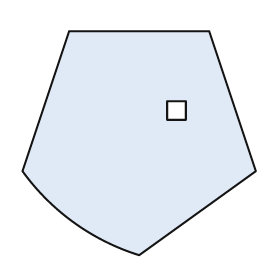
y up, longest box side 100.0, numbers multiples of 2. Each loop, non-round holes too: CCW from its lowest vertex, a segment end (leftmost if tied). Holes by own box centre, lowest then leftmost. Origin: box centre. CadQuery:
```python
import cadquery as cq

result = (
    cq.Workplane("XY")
    .moveTo(0.0, -48.0)
    .lineTo(50.0, -12.0)
    .lineTo(30.0, 48.0)
    .lineTo(-30.0, 48.0)
    .lineTo(-50.0, -12.0)
    .threePointArc((-28.0, -34.0), (0.0, -48.0))
    .close()
    .moveTo(12.0, 10.0)
    .lineTo(20.0, 10.0)
    .lineTo(20.0, 18.0)
    .lineTo(12.0, 18.0)
    .close()
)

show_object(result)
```